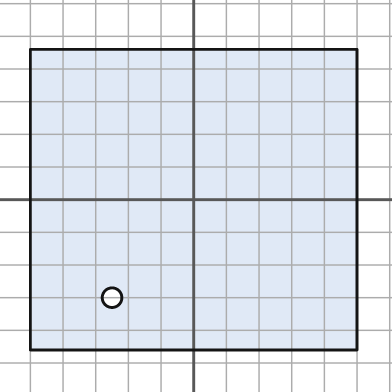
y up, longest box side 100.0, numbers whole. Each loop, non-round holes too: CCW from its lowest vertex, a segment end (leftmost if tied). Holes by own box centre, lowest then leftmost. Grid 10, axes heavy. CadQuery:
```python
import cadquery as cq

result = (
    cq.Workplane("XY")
    .moveTo(-50.0, -46.0)
    .lineTo(50.0, -46.0)
    .lineTo(50.0, 46.0)
    .lineTo(-50.0, 46.0)
    .close()
    .moveTo(-25.0, -30.0)
    .circle(3.0)
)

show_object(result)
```